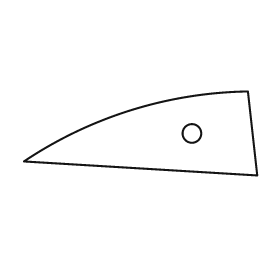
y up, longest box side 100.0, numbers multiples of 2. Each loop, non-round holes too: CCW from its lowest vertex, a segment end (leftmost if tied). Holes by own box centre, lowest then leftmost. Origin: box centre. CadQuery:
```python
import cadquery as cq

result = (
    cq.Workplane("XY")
    .moveTo(50.0, -18.0)
    .lineTo(46.0, 18.0)
    .threePointArc((-4.0, 10.0), (-50.0, -12.0))
    .close()
    .moveTo(22.0, 0.0)
    .circle(4.0)
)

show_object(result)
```